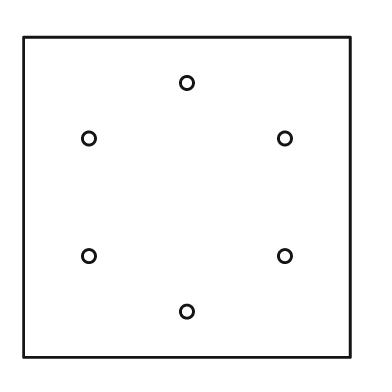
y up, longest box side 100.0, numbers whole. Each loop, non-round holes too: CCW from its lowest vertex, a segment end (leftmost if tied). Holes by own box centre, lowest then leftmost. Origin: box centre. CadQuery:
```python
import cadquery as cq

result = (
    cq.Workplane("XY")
    .moveTo(-50.0, -49.0)
    .lineTo(50.0, -49.0)
    .lineTo(50.0, 49.0)
    .lineTo(-50.0, 49.0)
    .close()
    .moveTo(0.0, -35.0)
    .circle(2.0)
    .moveTo(-30.0, -18.0)
    .circle(2.0)
    .moveTo(30.0, -18.0)
    .circle(2.0)
    .moveTo(-30.0, 18.0)
    .circle(2.0)
    .moveTo(30.0, 18.0)
    .circle(2.0)
    .moveTo(0.0, 35.0)
    .circle(2.0)
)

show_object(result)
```